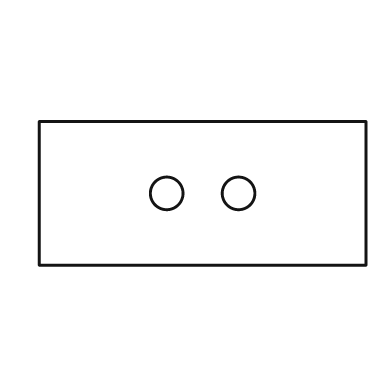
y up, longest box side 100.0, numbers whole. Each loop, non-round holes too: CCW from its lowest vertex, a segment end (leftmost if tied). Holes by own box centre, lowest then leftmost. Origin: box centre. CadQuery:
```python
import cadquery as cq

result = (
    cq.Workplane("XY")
    .moveTo(-50.0, -22.0)
    .lineTo(50.0, -22.0)
    .lineTo(50.0, 22.0)
    .lineTo(-50.0, 22.0)
    .close()
    .moveTo(-11.0, 0.0)
    .circle(5.0)
    .moveTo(11.0, 0.0)
    .circle(5.0)
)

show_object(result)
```